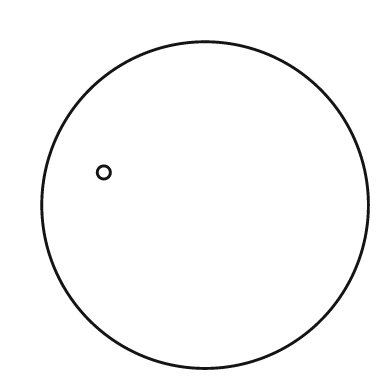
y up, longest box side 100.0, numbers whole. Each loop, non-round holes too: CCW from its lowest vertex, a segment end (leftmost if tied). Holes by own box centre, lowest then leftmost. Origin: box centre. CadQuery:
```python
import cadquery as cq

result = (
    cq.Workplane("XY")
    .moveTo(0.0, 0.0)
    .circle(50.0)
    .moveTo(-31.0, 10.0)
    .circle(2.0)
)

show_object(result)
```